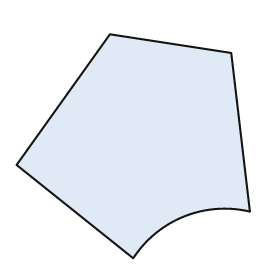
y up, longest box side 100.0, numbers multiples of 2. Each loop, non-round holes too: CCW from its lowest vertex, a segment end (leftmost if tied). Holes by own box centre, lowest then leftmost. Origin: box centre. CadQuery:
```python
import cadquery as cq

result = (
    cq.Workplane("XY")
    .moveTo(0.0, -48.0)
    .threePointArc((22.0, -30.0), (50.0, -28.0))
    .lineTo(42.0, 40.0)
    .lineTo(-10.0, 48.0)
    .lineTo(-50.0, -8.0)
    .close()
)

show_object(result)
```